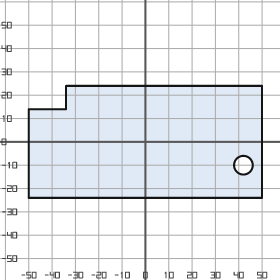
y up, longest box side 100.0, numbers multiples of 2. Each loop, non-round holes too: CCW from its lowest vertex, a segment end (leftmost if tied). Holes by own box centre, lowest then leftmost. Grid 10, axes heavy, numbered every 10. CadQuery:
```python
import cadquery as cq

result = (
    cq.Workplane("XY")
    .moveTo(-50.0, -24.0)
    .lineTo(50.0, -24.0)
    .lineTo(50.0, 24.0)
    .lineTo(-34.0, 24.0)
    .lineTo(-34.0, 14.0)
    .lineTo(-50.0, 14.0)
    .close()
    .moveTo(42.0, -10.0)
    .circle(4.0)
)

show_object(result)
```